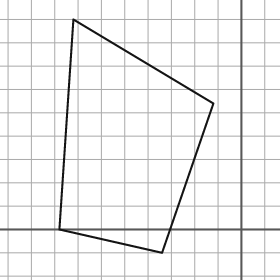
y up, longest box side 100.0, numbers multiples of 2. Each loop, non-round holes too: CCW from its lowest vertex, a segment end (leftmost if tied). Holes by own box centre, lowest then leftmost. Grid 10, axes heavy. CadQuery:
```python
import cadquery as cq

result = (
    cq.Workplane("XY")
    .moveTo(-34.0, -10.0)
    .lineTo(-12.0, 54.0)
    .lineTo(-72.0, 90.0)
    .lineTo(-78.0, 0.0)
    .close()
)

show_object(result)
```